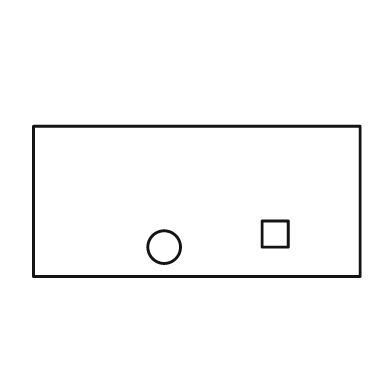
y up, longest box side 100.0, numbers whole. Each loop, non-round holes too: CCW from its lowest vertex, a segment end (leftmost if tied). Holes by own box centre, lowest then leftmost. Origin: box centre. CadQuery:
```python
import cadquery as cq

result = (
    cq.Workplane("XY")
    .moveTo(-50.0, -23.0)
    .lineTo(50.0, -23.0)
    .lineTo(50.0, 23.0)
    .lineTo(-50.0, 23.0)
    .close()
    .moveTo(-10.0, -14.0)
    .circle(5.0)
    .moveTo(20.0, -14.0)
    .lineTo(28.0, -14.0)
    .lineTo(28.0, -6.0)
    .lineTo(20.0, -6.0)
    .close()
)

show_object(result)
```